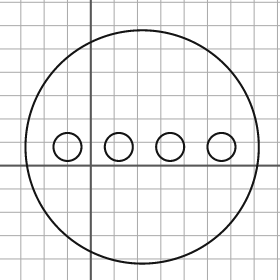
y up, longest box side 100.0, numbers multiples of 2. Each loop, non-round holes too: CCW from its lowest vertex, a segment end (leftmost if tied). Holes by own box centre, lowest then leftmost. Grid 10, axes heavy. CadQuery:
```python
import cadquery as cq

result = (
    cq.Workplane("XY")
    .moveTo(22.0, 8.0)
    .circle(50.0)
    .moveTo(-10.0, 8.0)
    .circle(6.0)
    .moveTo(12.0, 8.0)
    .circle(6.0)
    .moveTo(34.0, 8.0)
    .circle(6.0)
    .moveTo(56.0, 8.0)
    .circle(6.0)
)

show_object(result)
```